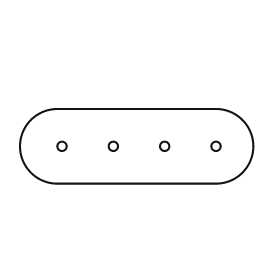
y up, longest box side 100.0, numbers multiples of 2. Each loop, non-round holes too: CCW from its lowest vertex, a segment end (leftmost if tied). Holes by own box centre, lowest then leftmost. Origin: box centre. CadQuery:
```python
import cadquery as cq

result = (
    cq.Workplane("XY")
    .moveTo(-34.0, -16.0)
    .lineTo(34.0, -16.0)
    .threePointArc((50.0, 0.0), (34.0, 16.0))
    .lineTo(-34.0, 16.0)
    .threePointArc((-50.0, 0.0), (-34.0, -16.0))
    .close()
    .moveTo(-32.0, 0.0)
    .circle(2.0)
    .moveTo(-10.0, 0.0)
    .circle(2.0)
    .moveTo(12.0, 0.0)
    .circle(2.0)
    .moveTo(34.0, 0.0)
    .circle(2.0)
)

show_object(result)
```